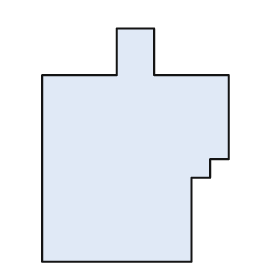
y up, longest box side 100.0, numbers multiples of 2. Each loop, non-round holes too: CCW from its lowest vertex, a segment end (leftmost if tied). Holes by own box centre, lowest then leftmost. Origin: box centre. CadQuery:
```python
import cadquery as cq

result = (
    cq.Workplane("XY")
    .moveTo(-40.0, -50.0)
    .lineTo(24.0, -50.0)
    .lineTo(24.0, -14.0)
    .lineTo(32.0, -14.0)
    .lineTo(32.0, -6.0)
    .lineTo(40.0, -6.0)
    .lineTo(40.0, 30.0)
    .lineTo(8.0, 30.0)
    .lineTo(8.0, 50.0)
    .lineTo(-8.0, 50.0)
    .lineTo(-8.0, 30.0)
    .lineTo(-40.0, 30.0)
    .close()
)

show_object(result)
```